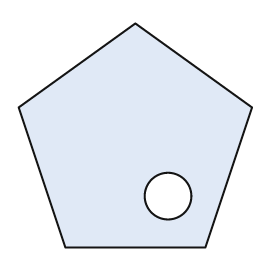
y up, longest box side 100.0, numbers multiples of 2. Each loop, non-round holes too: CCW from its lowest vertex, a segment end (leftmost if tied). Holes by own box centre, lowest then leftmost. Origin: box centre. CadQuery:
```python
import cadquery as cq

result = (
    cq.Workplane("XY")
    .moveTo(-30.0, -48.0)
    .lineTo(30.0, -48.0)
    .lineTo(50.0, 12.0)
    .lineTo(0.0, 48.0)
    .lineTo(-50.0, 12.0)
    .close()
    .moveTo(14.0, -26.0)
    .circle(10.0)
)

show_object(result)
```